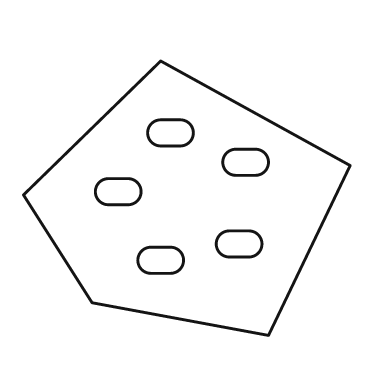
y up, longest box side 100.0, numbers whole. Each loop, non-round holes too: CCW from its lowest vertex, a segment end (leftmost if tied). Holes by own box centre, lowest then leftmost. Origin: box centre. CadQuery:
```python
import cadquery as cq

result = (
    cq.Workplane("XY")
    .moveTo(25.0, -42.0)
    .lineTo(50.0, 10.0)
    .lineTo(-8.0, 42.0)
    .lineTo(-50.0, 1.0)
    .lineTo(-29.0, -32.0)
    .close()
    .moveTo(-11.0, -23.0)
    .lineTo(-5.0, -23.0)
    .threePointArc((-1.0, -19.0), (-5.0, -15.0))
    .lineTo(-11.0, -15.0)
    .threePointArc((-15.0, -19.0), (-11.0, -23.0))
    .close()
    .moveTo(13.0, -18.0)
    .lineTo(19.0, -18.0)
    .threePointArc((23.0, -14.0), (19.0, -10.0))
    .lineTo(13.0, -10.0)
    .threePointArc((9.0, -14.0), (13.0, -18.0))
    .close()
    .moveTo(-24.0, -2.0)
    .lineTo(-18.0, -2.0)
    .threePointArc((-14.0, 2.0), (-18.0, 6.0))
    .lineTo(-24.0, 6.0)
    .threePointArc((-28.0, 2.0), (-24.0, -2.0))
    .close()
    .moveTo(15.0, 7.0)
    .lineTo(21.0, 7.0)
    .threePointArc((25.0, 11.0), (21.0, 15.0))
    .lineTo(15.0, 15.0)
    .threePointArc((11.0, 11.0), (15.0, 7.0))
    .close()
    .moveTo(-8.0, 16.0)
    .lineTo(-2.0, 16.0)
    .threePointArc((2.0, 20.0), (-2.0, 24.0))
    .lineTo(-8.0, 24.0)
    .threePointArc((-12.0, 20.0), (-8.0, 16.0))
    .close()
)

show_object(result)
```